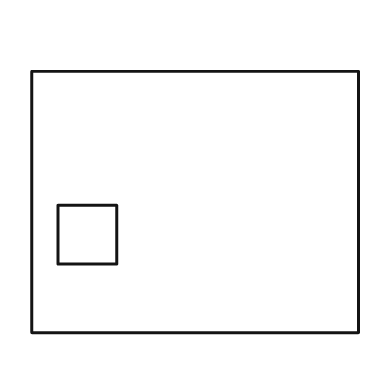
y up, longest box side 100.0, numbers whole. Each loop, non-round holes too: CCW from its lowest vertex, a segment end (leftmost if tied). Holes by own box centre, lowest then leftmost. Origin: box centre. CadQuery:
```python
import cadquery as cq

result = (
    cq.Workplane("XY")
    .moveTo(-50.0, -40.0)
    .lineTo(50.0, -40.0)
    .lineTo(50.0, 40.0)
    .lineTo(-50.0, 40.0)
    .close()
    .moveTo(-42.0, -19.0)
    .lineTo(-24.0, -19.0)
    .lineTo(-24.0, -1.0)
    .lineTo(-42.0, -1.0)
    .close()
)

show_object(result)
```